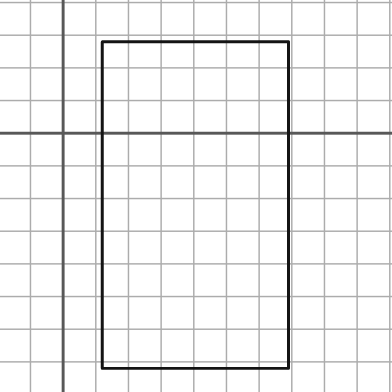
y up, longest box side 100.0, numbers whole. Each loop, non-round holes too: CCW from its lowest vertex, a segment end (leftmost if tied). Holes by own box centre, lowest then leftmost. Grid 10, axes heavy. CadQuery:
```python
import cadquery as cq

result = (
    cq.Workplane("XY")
    .moveTo(12.0, -72.0)
    .lineTo(69.0, -72.0)
    .lineTo(69.0, 28.0)
    .lineTo(12.0, 28.0)
    .close()
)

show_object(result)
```